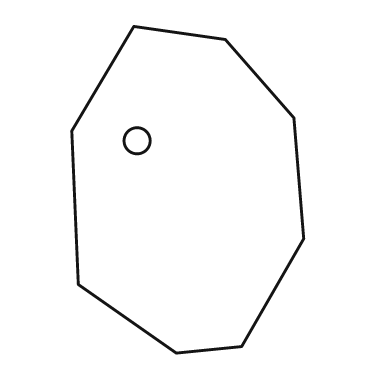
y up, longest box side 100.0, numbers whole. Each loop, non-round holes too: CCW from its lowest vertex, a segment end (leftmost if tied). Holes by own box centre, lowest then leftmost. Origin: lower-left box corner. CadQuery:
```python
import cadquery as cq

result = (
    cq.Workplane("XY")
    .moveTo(32.0, 0.0)
    .lineTo(52.0, 2.0)
    .lineTo(71.0, 35.0)
    .lineTo(68.0, 72.0)
    .lineTo(47.0, 96.0)
    .lineTo(19.0, 100.0)
    .lineTo(0.0, 68.0)
    .lineTo(2.0, 21.0)
    .close()
    .moveTo(20.0, 65.0)
    .circle(4.0)
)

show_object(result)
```